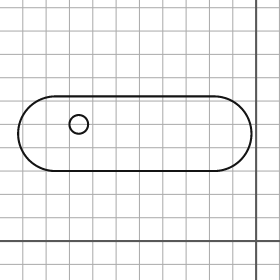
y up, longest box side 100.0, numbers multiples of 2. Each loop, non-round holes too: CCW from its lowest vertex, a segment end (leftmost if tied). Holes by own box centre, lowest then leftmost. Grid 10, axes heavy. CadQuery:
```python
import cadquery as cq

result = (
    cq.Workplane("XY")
    .moveTo(-86.0, 30.0)
    .lineTo(-18.0, 30.0)
    .threePointArc((-2.0, 46.0), (-18.0, 62.0))
    .lineTo(-86.0, 62.0)
    .threePointArc((-102.0, 46.0), (-86.0, 30.0))
    .close()
    .moveTo(-76.0, 50.0)
    .circle(4.0)
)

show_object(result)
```